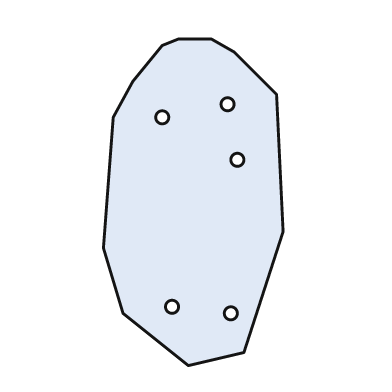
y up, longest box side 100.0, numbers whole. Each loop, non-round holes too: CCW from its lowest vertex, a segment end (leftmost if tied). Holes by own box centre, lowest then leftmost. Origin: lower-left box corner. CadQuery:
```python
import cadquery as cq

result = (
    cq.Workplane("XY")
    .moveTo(26.0, 0.0)
    .lineTo(43.0, 4.0)
    .lineTo(55.0, 41.0)
    .lineTo(53.0, 83.0)
    .lineTo(40.0, 96.0)
    .lineTo(33.0, 100.0)
    .lineTo(23.0, 100.0)
    .lineTo(18.0, 98.0)
    .lineTo(9.0, 87.0)
    .lineTo(3.0, 76.0)
    .lineTo(0.0, 36.0)
    .lineTo(6.0, 16.0)
    .close()
    .moveTo(39.0, 16.0)
    .circle(2.0)
    .moveTo(21.0, 18.0)
    .circle(2.0)
    .moveTo(41.0, 63.0)
    .circle(2.0)
    .moveTo(18.0, 76.0)
    .circle(2.0)
    .moveTo(38.0, 80.0)
    .circle(2.0)
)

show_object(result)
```